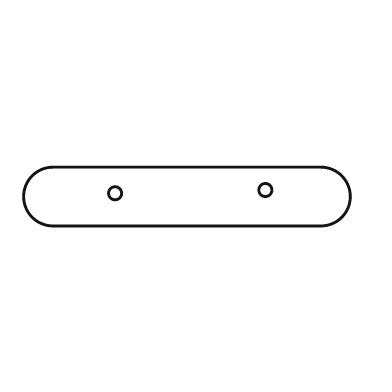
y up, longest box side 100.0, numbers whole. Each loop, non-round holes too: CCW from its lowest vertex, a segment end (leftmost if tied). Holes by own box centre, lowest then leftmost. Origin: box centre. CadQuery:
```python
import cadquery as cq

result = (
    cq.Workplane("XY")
    .moveTo(-41.0, -9.0)
    .lineTo(41.0, -9.0)
    .threePointArc((50.0, 0.0), (41.0, 9.0))
    .lineTo(-41.0, 9.0)
    .threePointArc((-50.0, 0.0), (-41.0, -9.0))
    .close()
    .moveTo(-22.0, 1.0)
    .circle(2.0)
    .moveTo(24.0, 2.0)
    .circle(2.0)
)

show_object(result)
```